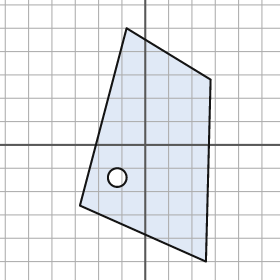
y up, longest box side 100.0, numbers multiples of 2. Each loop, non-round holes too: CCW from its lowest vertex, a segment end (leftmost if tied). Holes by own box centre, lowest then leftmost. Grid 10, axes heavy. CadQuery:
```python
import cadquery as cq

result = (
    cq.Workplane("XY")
    .moveTo(26.0, -50.0)
    .lineTo(28.0, 28.0)
    .lineTo(-8.0, 50.0)
    .lineTo(-28.0, -26.0)
    .close()
    .moveTo(-12.0, -14.0)
    .circle(4.0)
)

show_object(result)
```